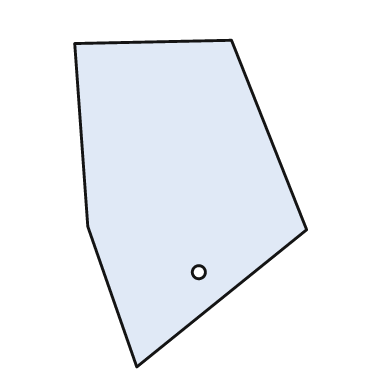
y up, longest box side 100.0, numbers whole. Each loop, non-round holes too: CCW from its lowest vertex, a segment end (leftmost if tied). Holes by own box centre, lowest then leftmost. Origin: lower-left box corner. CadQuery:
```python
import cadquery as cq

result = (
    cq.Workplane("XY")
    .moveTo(19.0, 0.0)
    .lineTo(71.0, 42.0)
    .lineTo(48.0, 100.0)
    .lineTo(0.0, 99.0)
    .lineTo(4.0, 43.0)
    .close()
    .moveTo(38.0, 29.0)
    .circle(2.0)
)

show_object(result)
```